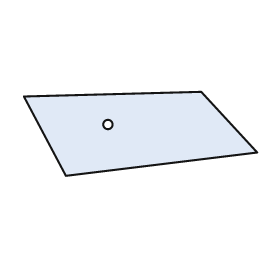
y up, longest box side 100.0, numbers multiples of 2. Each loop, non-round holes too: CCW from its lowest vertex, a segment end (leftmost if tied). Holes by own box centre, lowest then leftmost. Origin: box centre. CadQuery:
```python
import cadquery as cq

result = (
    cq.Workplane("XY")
    .moveTo(-32.0, -18.0)
    .lineTo(50.0, -8.0)
    .lineTo(26.0, 18.0)
    .lineTo(-50.0, 16.0)
    .close()
    .moveTo(-14.0, 4.0)
    .circle(2.0)
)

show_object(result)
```